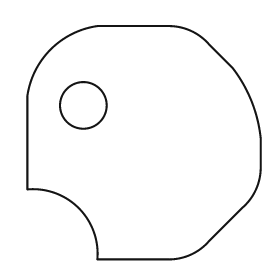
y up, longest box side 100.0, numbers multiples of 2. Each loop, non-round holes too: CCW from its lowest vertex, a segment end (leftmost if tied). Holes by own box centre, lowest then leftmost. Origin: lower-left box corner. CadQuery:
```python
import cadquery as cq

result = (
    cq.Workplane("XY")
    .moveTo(30.0, 0.0)
    .lineTo(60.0, 0.0)
    .threePointArc((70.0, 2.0), (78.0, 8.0))
    .lineTo(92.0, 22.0)
    .threePointArc((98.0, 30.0), (100.0, 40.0))
    .lineTo(100.0, 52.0)
    .threePointArc((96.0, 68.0), (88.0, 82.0))
    .lineTo(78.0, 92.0)
    .threePointArc((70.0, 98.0), (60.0, 100.0))
    .lineTo(30.0, 100.0)
    .threePointArc((10.0, 90.0), (0.0, 70.0))
    .lineTo(0.0, 30.0)
    .threePointArc((22.0, 22.0), (30.0, 0.0))
    .close()
    .moveTo(24.0, 66.0)
    .circle(10.0)
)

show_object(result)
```